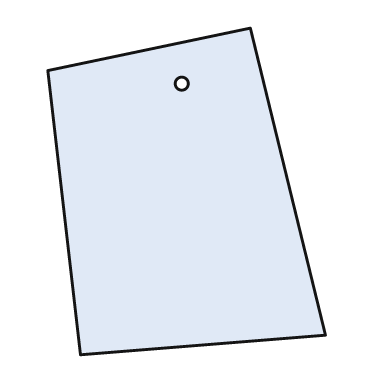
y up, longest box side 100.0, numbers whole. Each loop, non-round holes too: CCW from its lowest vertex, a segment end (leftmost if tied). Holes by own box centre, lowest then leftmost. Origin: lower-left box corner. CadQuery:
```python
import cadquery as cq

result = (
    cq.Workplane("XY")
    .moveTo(10.0, 0.0)
    .lineTo(85.0, 6.0)
    .lineTo(62.0, 100.0)
    .lineTo(0.0, 87.0)
    .close()
    .moveTo(41.0, 83.0)
    .circle(2.0)
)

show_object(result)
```